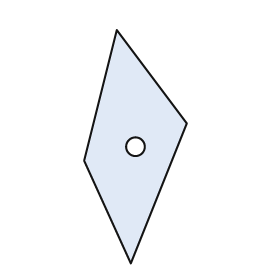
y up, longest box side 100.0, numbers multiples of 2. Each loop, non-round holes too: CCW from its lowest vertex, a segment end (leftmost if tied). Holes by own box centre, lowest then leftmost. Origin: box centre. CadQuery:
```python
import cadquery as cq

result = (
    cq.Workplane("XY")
    .moveTo(-2.0, -50.0)
    .lineTo(22.0, 10.0)
    .lineTo(-8.0, 50.0)
    .lineTo(-22.0, -6.0)
    .close()
    .moveTo(0.0, 0.0)
    .circle(4.0)
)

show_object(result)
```